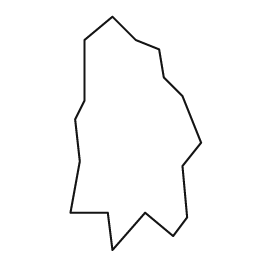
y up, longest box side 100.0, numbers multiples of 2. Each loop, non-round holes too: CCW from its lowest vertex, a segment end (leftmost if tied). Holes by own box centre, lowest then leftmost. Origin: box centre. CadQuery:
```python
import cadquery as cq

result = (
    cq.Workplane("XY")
    .moveTo(-10.0, -50.0)
    .lineTo(4.0, -34.0)
    .lineTo(16.0, -44.0)
    .lineTo(22.0, -36.0)
    .lineTo(20.0, -14.0)
    .lineTo(28.0, -4.0)
    .lineTo(20.0, 16.0)
    .lineTo(12.0, 24.0)
    .lineTo(10.0, 36.0)
    .lineTo(0.0, 40.0)
    .lineTo(-10.0, 50.0)
    .lineTo(-22.0, 40.0)
    .lineTo(-22.0, 14.0)
    .lineTo(-26.0, 6.0)
    .lineTo(-24.0, -12.0)
    .lineTo(-28.0, -34.0)
    .lineTo(-12.0, -34.0)
    .close()
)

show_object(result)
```